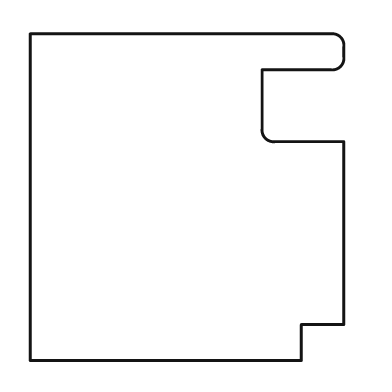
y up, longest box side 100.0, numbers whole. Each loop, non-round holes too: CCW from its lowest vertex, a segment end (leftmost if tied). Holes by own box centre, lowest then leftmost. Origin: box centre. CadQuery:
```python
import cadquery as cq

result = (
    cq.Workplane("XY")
    .moveTo(-48.0, -50.0)
    .lineTo(35.0, -50.0)
    .lineTo(35.0, -39.0)
    .lineTo(48.0, -39.0)
    .lineTo(48.0, 17.0)
    .lineTo(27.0, 17.0)
    .threePointArc((24.0, 18.0), (23.0, 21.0))
    .lineTo(23.0, 39.0)
    .lineTo(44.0, 39.0)
    .threePointArc((47.0, 40.0), (48.0, 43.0))
    .lineTo(48.0, 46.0)
    .threePointArc((47.0, 49.0), (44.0, 50.0))
    .lineTo(-48.0, 50.0)
    .close()
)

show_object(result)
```